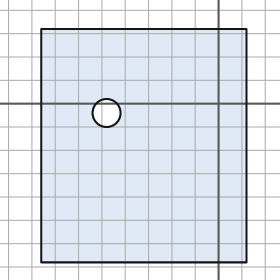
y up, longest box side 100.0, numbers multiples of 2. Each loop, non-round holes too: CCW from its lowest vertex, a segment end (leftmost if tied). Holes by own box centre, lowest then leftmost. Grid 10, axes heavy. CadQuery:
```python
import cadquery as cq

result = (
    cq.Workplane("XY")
    .moveTo(-76.0, -68.0)
    .lineTo(12.0, -68.0)
    .lineTo(12.0, 32.0)
    .lineTo(-76.0, 32.0)
    .close()
    .moveTo(-48.0, -4.0)
    .circle(6.0)
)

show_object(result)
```